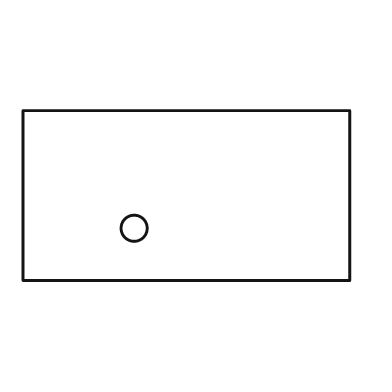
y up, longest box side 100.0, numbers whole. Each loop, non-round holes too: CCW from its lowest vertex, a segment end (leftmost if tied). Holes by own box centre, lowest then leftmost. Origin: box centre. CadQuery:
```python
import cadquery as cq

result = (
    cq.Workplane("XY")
    .moveTo(-50.0, -26.0)
    .lineTo(50.0, -26.0)
    .lineTo(50.0, 26.0)
    .lineTo(-50.0, 26.0)
    .close()
    .moveTo(-16.0, -10.0)
    .circle(4.0)
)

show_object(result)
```